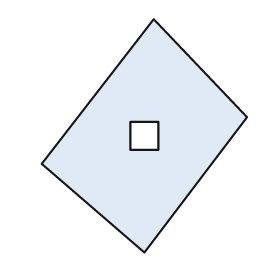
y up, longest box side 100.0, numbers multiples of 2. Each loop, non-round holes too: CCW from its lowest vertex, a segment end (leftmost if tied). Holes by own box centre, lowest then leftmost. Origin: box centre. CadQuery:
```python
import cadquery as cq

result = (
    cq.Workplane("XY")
    .moveTo(0.0, -50.0)
    .lineTo(44.0, 8.0)
    .lineTo(4.0, 50.0)
    .lineTo(-44.0, -12.0)
    .close()
    .moveTo(-6.0, -6.0)
    .lineTo(6.0, -6.0)
    .lineTo(6.0, 6.0)
    .lineTo(-6.0, 6.0)
    .close()
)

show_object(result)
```